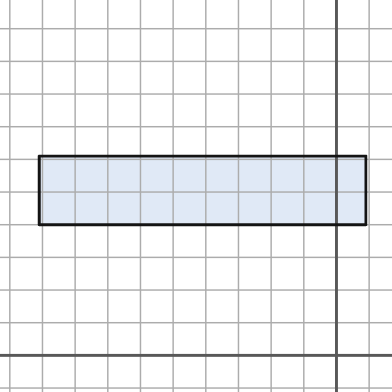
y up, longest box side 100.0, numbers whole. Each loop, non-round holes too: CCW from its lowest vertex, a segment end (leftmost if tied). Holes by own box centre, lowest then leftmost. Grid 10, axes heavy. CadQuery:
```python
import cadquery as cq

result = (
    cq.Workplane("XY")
    .moveTo(-91.0, 40.0)
    .lineTo(9.0, 40.0)
    .lineTo(9.0, 61.0)
    .lineTo(-91.0, 61.0)
    .close()
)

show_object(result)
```